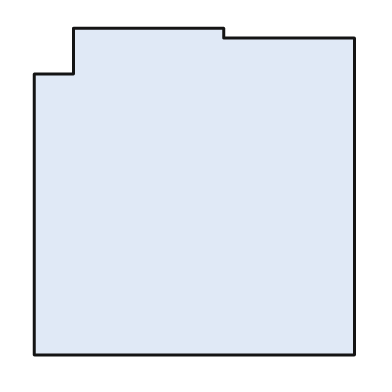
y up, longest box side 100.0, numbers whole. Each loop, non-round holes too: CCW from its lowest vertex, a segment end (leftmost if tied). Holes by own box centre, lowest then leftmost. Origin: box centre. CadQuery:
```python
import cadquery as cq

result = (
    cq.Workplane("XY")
    .moveTo(-49.0, -50.0)
    .lineTo(49.0, -50.0)
    .lineTo(49.0, 47.0)
    .lineTo(9.0, 47.0)
    .lineTo(9.0, 50.0)
    .lineTo(-37.0, 50.0)
    .lineTo(-37.0, 36.0)
    .lineTo(-49.0, 36.0)
    .close()
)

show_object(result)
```